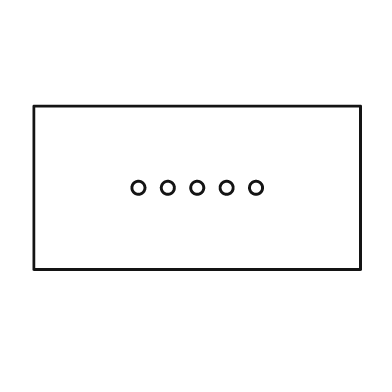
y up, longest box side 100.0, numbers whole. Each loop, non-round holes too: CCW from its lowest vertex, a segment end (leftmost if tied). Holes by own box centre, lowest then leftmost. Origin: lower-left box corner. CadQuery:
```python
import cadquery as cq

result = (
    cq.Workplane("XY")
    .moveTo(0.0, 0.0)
    .lineTo(100.0, 0.0)
    .lineTo(100.0, 50.0)
    .lineTo(0.0, 50.0)
    .close()
    .moveTo(32.0, 25.0)
    .circle(2.0)
    .moveTo(41.0, 25.0)
    .circle(2.0)
    .moveTo(50.0, 25.0)
    .circle(2.0)
    .moveTo(59.0, 25.0)
    .circle(2.0)
    .moveTo(68.0, 25.0)
    .circle(2.0)
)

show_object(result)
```